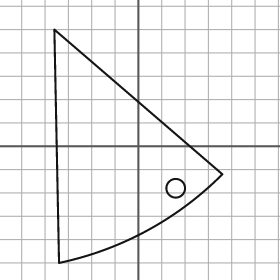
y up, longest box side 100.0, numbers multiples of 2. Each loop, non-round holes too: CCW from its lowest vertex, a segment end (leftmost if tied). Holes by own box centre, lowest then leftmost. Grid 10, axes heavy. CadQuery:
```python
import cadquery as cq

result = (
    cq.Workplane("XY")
    .moveTo(-34.0, -50.0)
    .threePointArc((4.0, -36.0), (36.0, -12.0))
    .lineTo(-36.0, 50.0)
    .close()
    .moveTo(16.0, -18.0)
    .circle(4.0)
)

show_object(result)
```